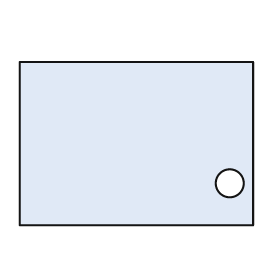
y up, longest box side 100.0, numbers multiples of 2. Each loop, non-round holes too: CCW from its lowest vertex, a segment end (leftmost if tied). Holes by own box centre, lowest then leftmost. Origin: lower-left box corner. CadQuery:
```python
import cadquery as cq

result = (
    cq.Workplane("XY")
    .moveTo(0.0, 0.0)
    .lineTo(100.0, 0.0)
    .lineTo(100.0, 70.0)
    .lineTo(0.0, 70.0)
    .close()
    .moveTo(90.0, 18.0)
    .circle(6.0)
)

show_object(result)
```